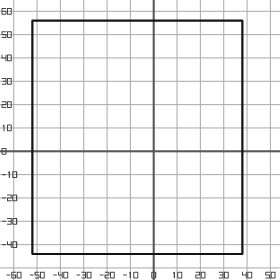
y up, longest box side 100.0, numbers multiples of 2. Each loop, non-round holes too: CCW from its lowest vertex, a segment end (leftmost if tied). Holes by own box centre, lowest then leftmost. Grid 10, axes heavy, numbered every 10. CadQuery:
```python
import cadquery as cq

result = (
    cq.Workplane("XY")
    .moveTo(-52.0, -44.0)
    .lineTo(38.0, -44.0)
    .lineTo(38.0, 56.0)
    .lineTo(-52.0, 56.0)
    .close()
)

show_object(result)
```